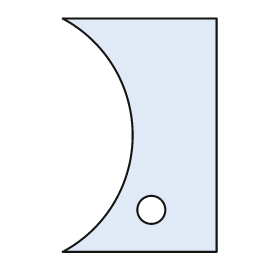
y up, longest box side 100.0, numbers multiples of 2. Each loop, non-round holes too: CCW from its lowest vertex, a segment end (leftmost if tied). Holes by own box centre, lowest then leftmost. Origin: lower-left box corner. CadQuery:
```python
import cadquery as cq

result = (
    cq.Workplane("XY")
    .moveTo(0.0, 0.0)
    .lineTo(66.0, 0.0)
    .lineTo(66.0, 100.0)
    .lineTo(0.0, 100.0)
    .threePointArc((30.0, 50.0), (0.0, 0.0))
    .close()
    .moveTo(38.0, 18.0)
    .circle(6.0)
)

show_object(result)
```